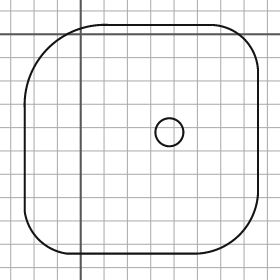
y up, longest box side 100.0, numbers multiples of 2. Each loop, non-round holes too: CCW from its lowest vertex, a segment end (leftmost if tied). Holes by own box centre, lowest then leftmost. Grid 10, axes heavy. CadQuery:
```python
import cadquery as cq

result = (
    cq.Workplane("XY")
    .moveTo(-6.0, -94.0)
    .lineTo(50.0, -94.0)
    .threePointArc((68.0, -86.0), (76.0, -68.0))
    .lineTo(76.0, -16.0)
    .threePointArc((70.0, -2.0), (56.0, 4.0))
    .lineTo(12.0, 4.0)
    .threePointArc((-14.0, -6.0), (-24.0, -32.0))
    .lineTo(-24.0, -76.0)
    .threePointArc((-18.0, -88.0), (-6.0, -94.0))
    .close()
    .moveTo(38.0, -42.0)
    .circle(6.0)
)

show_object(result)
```